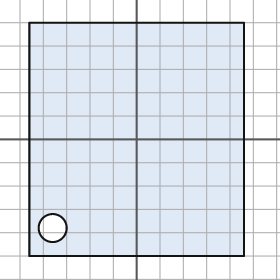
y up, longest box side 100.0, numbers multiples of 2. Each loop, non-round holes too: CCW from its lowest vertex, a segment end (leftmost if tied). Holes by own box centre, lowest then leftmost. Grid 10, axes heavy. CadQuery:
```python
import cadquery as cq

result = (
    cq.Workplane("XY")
    .moveTo(-46.0, -50.0)
    .lineTo(46.0, -50.0)
    .lineTo(46.0, 50.0)
    .lineTo(-46.0, 50.0)
    .close()
    .moveTo(-36.0, -38.0)
    .circle(6.0)
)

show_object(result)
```